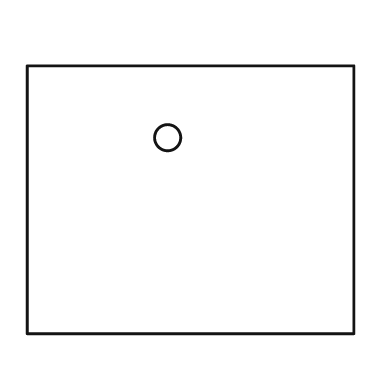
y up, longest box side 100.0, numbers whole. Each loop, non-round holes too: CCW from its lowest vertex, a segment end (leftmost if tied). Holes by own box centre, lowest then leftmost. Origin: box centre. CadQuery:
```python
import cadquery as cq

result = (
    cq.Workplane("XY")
    .moveTo(-50.0, -41.0)
    .lineTo(50.0, -41.0)
    .lineTo(50.0, 41.0)
    .lineTo(-50.0, 41.0)
    .close()
    .moveTo(-7.0, 19.0)
    .circle(4.0)
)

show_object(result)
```